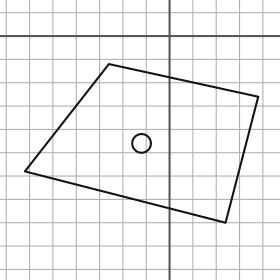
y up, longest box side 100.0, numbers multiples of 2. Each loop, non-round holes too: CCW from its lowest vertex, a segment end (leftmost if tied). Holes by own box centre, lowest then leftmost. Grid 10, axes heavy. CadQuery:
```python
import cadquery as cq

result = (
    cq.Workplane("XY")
    .moveTo(24.0, -80.0)
    .lineTo(38.0, -26.0)
    .lineTo(-26.0, -12.0)
    .lineTo(-62.0, -58.0)
    .close()
    .moveTo(-12.0, -46.0)
    .circle(4.0)
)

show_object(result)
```